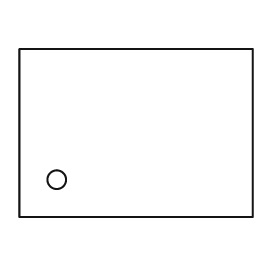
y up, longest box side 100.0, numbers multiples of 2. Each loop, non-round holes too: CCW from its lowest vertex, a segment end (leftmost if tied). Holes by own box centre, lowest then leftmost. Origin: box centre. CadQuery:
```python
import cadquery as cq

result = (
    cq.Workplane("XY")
    .moveTo(-50.0, -36.0)
    .lineTo(50.0, -36.0)
    .lineTo(50.0, 36.0)
    .lineTo(-50.0, 36.0)
    .close()
    .moveTo(-34.0, -20.0)
    .circle(4.0)
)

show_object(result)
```